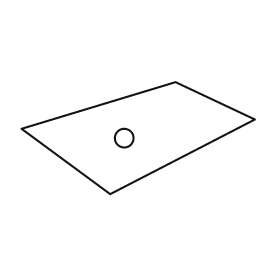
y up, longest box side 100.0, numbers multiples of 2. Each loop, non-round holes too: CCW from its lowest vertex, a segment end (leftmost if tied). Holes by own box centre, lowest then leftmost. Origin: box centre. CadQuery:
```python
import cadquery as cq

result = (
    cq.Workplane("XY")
    .moveTo(-12.0, -24.0)
    .lineTo(50.0, 8.0)
    .lineTo(16.0, 24.0)
    .lineTo(-50.0, 4.0)
    .close()
    .moveTo(-6.0, 0.0)
    .circle(4.0)
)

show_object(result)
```